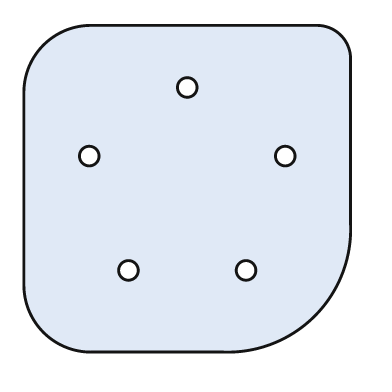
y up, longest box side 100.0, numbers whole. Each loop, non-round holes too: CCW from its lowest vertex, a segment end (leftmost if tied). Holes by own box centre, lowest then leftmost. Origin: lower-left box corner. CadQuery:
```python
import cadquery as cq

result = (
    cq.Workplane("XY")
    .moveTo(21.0, 0.0)
    .lineTo(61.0, 0.0)
    .threePointArc((89.0, 11.0), (100.0, 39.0))
    .lineTo(100.0, 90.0)
    .threePointArc((97.0, 97.0), (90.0, 100.0))
    .lineTo(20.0, 100.0)
    .threePointArc((6.0, 94.0), (0.0, 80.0))
    .lineTo(0.0, 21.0)
    .threePointArc((6.0, 6.0), (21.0, 0.0))
    .close()
    .moveTo(32.0, 25.0)
    .circle(3.0)
    .moveTo(68.0, 25.0)
    .circle(3.0)
    .moveTo(20.0, 60.0)
    .circle(3.0)
    .moveTo(80.0, 60.0)
    .circle(3.0)
    .moveTo(50.0, 81.0)
    .circle(3.0)
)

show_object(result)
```